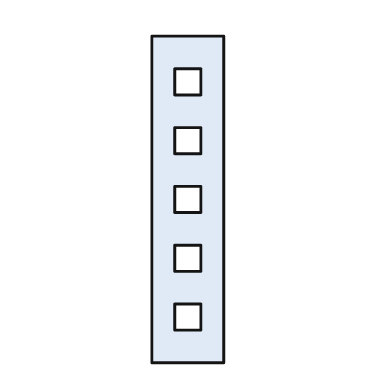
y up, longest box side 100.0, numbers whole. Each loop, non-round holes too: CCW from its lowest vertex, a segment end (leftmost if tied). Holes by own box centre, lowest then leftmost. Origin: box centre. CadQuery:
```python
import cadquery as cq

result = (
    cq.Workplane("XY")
    .moveTo(-11.0, -50.0)
    .lineTo(11.0, -50.0)
    .lineTo(11.0, 50.0)
    .lineTo(-11.0, 50.0)
    .close()
    .moveTo(-4.0, -40.0)
    .lineTo(4.0, -40.0)
    .lineTo(4.0, -32.0)
    .lineTo(-4.0, -32.0)
    .close()
    .moveTo(-4.0, -22.0)
    .lineTo(4.0, -22.0)
    .lineTo(4.0, -14.0)
    .lineTo(-4.0, -14.0)
    .close()
    .moveTo(-4.0, -4.0)
    .lineTo(4.0, -4.0)
    .lineTo(4.0, 4.0)
    .lineTo(-4.0, 4.0)
    .close()
    .moveTo(-4.0, 14.0)
    .lineTo(4.0, 14.0)
    .lineTo(4.0, 22.0)
    .lineTo(-4.0, 22.0)
    .close()
    .moveTo(-4.0, 32.0)
    .lineTo(4.0, 32.0)
    .lineTo(4.0, 40.0)
    .lineTo(-4.0, 40.0)
    .close()
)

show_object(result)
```